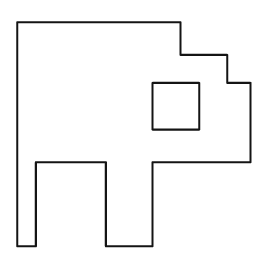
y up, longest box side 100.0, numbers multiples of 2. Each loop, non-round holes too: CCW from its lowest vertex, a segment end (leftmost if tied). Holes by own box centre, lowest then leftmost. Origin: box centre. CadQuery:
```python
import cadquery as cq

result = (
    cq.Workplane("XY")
    .moveTo(-50.0, -48.0)
    .lineTo(-42.0, -48.0)
    .lineTo(-42.0, -12.0)
    .lineTo(-12.0, -12.0)
    .lineTo(-12.0, -48.0)
    .lineTo(8.0, -48.0)
    .lineTo(8.0, -12.0)
    .lineTo(50.0, -12.0)
    .lineTo(50.0, 22.0)
    .lineTo(40.0, 22.0)
    .lineTo(40.0, 34.0)
    .lineTo(20.0, 34.0)
    .lineTo(20.0, 48.0)
    .lineTo(-50.0, 48.0)
    .close()
    .moveTo(8.0, 2.0)
    .lineTo(28.0, 2.0)
    .lineTo(28.0, 22.0)
    .lineTo(8.0, 22.0)
    .close()
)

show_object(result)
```